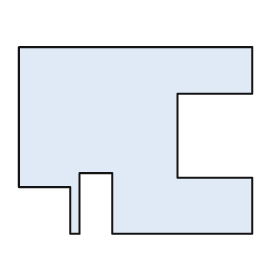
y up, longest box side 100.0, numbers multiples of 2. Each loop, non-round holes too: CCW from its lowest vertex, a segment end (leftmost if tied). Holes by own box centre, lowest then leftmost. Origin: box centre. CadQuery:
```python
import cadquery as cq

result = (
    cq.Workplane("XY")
    .moveTo(-28.0, -40.0)
    .lineTo(-24.0, -40.0)
    .lineTo(-24.0, -14.0)
    .lineTo(-10.0, -14.0)
    .lineTo(-10.0, -40.0)
    .lineTo(50.0, -40.0)
    .lineTo(50.0, -16.0)
    .lineTo(18.0, -16.0)
    .lineTo(18.0, 20.0)
    .lineTo(50.0, 20.0)
    .lineTo(50.0, 40.0)
    .lineTo(-50.0, 40.0)
    .lineTo(-50.0, -20.0)
    .lineTo(-28.0, -20.0)
    .close()
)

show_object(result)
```